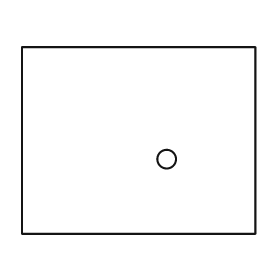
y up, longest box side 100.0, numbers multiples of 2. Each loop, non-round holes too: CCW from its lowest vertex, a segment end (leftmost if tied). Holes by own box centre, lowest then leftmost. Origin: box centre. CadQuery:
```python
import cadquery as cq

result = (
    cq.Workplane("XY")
    .moveTo(-50.0, -40.0)
    .lineTo(50.0, -40.0)
    .lineTo(50.0, 40.0)
    .lineTo(-50.0, 40.0)
    .close()
    .moveTo(12.0, -8.0)
    .circle(4.0)
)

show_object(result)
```